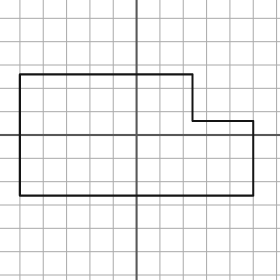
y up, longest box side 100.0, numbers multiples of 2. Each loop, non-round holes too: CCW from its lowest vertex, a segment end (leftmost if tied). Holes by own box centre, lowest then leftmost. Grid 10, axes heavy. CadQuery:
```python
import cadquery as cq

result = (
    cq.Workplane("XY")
    .moveTo(-50.0, -26.0)
    .lineTo(50.0, -26.0)
    .lineTo(50.0, 6.0)
    .lineTo(24.0, 6.0)
    .lineTo(24.0, 26.0)
    .lineTo(-50.0, 26.0)
    .close()
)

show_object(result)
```